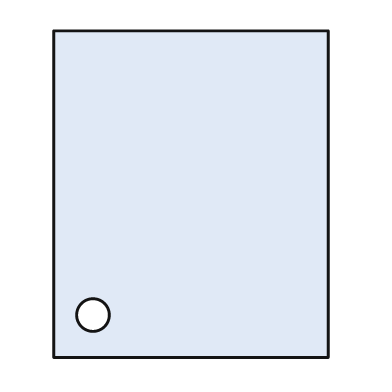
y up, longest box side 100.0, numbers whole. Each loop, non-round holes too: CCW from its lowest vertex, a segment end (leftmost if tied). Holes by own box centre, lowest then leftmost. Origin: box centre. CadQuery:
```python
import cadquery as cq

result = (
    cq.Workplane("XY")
    .moveTo(-42.0, -50.0)
    .lineTo(42.0, -50.0)
    .lineTo(42.0, 50.0)
    .lineTo(-42.0, 50.0)
    .close()
    .moveTo(-30.0, -37.0)
    .circle(5.0)
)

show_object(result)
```